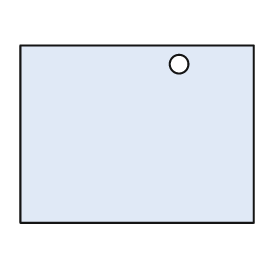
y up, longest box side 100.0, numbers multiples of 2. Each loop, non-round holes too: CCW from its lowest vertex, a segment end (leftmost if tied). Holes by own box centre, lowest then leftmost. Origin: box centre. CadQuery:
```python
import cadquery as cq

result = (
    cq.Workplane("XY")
    .moveTo(-50.0, -38.0)
    .lineTo(50.0, -38.0)
    .lineTo(50.0, 38.0)
    .lineTo(-50.0, 38.0)
    .close()
    .moveTo(18.0, 30.0)
    .circle(4.0)
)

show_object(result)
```